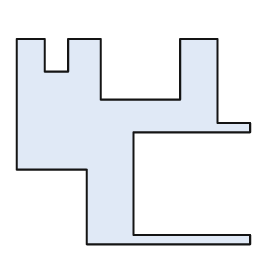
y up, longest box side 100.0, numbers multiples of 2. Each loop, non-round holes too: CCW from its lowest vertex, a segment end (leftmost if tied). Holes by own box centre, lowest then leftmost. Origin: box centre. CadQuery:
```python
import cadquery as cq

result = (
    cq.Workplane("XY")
    .moveTo(-20.0, -44.0)
    .lineTo(50.0, -44.0)
    .lineTo(50.0, -40.0)
    .lineTo(0.0, -40.0)
    .lineTo(0.0, 4.0)
    .lineTo(50.0, 4.0)
    .lineTo(50.0, 8.0)
    .lineTo(36.0, 8.0)
    .lineTo(36.0, 44.0)
    .lineTo(20.0, 44.0)
    .lineTo(20.0, 18.0)
    .lineTo(-14.0, 18.0)
    .lineTo(-14.0, 44.0)
    .lineTo(-28.0, 44.0)
    .lineTo(-28.0, 30.0)
    .lineTo(-38.0, 30.0)
    .lineTo(-38.0, 44.0)
    .lineTo(-50.0, 44.0)
    .lineTo(-50.0, -12.0)
    .lineTo(-20.0, -12.0)
    .close()
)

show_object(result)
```